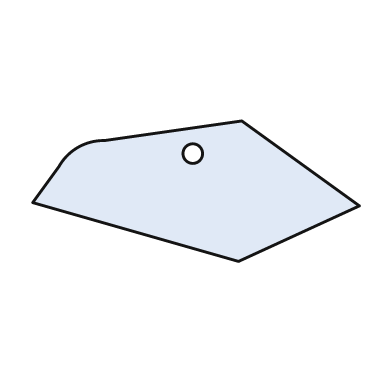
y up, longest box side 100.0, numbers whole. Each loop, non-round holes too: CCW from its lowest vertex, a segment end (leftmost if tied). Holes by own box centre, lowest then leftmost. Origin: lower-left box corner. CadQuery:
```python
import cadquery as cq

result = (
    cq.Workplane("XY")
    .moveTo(63.0, 0.0)
    .lineTo(100.0, 17.0)
    .lineTo(64.0, 43.0)
    .lineTo(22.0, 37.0)
    .threePointArc((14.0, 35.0), (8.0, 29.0))
    .lineTo(0.0, 18.0)
    .close()
    .moveTo(49.0, 33.0)
    .circle(3.0)
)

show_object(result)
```